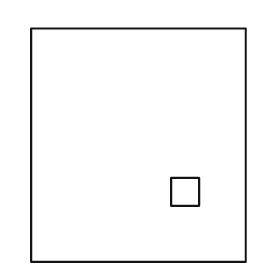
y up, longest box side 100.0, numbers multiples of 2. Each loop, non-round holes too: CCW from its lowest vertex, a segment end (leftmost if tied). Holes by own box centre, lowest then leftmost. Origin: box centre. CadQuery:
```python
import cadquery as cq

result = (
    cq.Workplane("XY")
    .moveTo(-46.0, -50.0)
    .lineTo(46.0, -50.0)
    .lineTo(46.0, 50.0)
    .lineTo(-46.0, 50.0)
    .close()
    .moveTo(14.0, -26.0)
    .lineTo(26.0, -26.0)
    .lineTo(26.0, -14.0)
    .lineTo(14.0, -14.0)
    .close()
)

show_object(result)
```